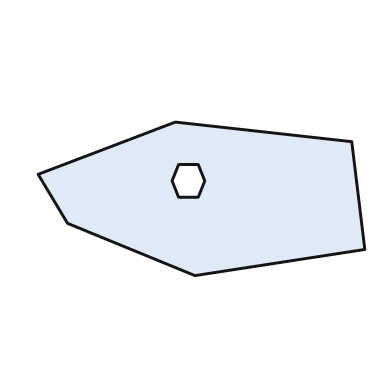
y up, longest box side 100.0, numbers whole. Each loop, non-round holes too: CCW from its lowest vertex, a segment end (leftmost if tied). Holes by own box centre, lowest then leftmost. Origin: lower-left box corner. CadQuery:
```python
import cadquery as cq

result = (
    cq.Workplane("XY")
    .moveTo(48.0, 0.0)
    .lineTo(100.0, 8.0)
    .lineTo(96.0, 41.0)
    .lineTo(42.0, 47.0)
    .lineTo(0.0, 31.0)
    .lineTo(9.0, 16.0)
    .close()
    .moveTo(43.0, 24.0)
    .lineTo(49.0, 24.0)
    .lineTo(51.0, 29.0)
    .lineTo(49.0, 34.0)
    .lineTo(43.0, 34.0)
    .lineTo(41.0, 29.0)
    .close()
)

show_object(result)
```